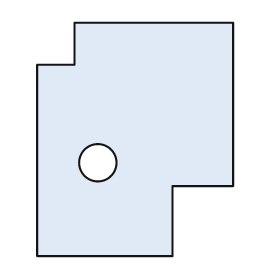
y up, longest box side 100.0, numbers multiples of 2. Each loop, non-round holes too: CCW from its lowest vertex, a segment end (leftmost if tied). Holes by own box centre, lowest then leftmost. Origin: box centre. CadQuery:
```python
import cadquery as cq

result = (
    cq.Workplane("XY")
    .moveTo(-42.0, -50.0)
    .lineTo(16.0, -50.0)
    .lineTo(16.0, -20.0)
    .lineTo(42.0, -20.0)
    .lineTo(42.0, 50.0)
    .lineTo(-26.0, 50.0)
    .lineTo(-26.0, 32.0)
    .lineTo(-42.0, 32.0)
    .close()
    .moveTo(-16.0, -10.0)
    .circle(8.0)
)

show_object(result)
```